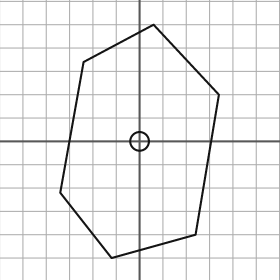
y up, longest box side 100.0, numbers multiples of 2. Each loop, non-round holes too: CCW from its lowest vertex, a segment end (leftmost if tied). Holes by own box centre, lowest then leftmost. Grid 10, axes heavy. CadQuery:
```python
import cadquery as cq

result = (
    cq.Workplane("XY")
    .moveTo(-12.0, -50.0)
    .lineTo(24.0, -40.0)
    .lineTo(34.0, 20.0)
    .lineTo(6.0, 50.0)
    .lineTo(-24.0, 34.0)
    .lineTo(-34.0, -22.0)
    .close()
    .moveTo(0.0, 0.0)
    .circle(4.0)
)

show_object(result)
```